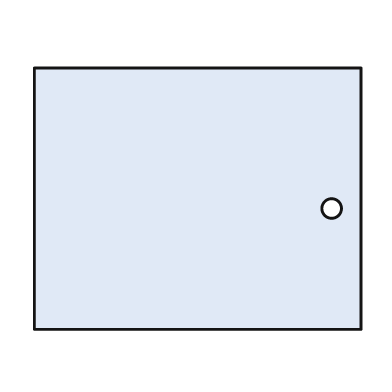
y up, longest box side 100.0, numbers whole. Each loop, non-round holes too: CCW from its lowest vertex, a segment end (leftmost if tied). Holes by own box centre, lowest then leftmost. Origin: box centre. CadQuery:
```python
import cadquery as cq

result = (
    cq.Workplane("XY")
    .moveTo(-50.0, -40.0)
    .lineTo(50.0, -40.0)
    .lineTo(50.0, 40.0)
    .lineTo(-50.0, 40.0)
    .close()
    .moveTo(41.0, -3.0)
    .circle(3.0)
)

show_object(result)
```